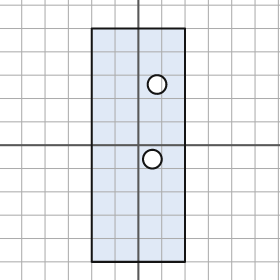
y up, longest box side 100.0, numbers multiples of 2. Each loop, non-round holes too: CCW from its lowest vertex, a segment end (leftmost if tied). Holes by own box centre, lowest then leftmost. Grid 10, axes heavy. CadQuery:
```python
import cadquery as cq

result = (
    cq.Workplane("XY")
    .moveTo(-20.0, -50.0)
    .lineTo(20.0, -50.0)
    .lineTo(20.0, 50.0)
    .lineTo(-20.0, 50.0)
    .close()
    .moveTo(6.0, -6.0)
    .circle(4.0)
    .moveTo(8.0, 26.0)
    .circle(4.0)
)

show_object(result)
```